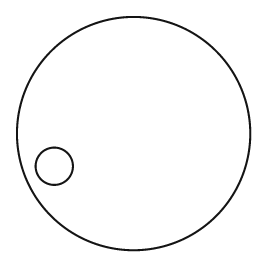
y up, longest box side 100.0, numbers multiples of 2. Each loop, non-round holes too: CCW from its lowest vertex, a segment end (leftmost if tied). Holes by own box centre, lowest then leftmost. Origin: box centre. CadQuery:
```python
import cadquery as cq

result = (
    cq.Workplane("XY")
    .moveTo(0.0, 0.0)
    .circle(50.0)
    .moveTo(-34.0, -14.0)
    .circle(8.0)
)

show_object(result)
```